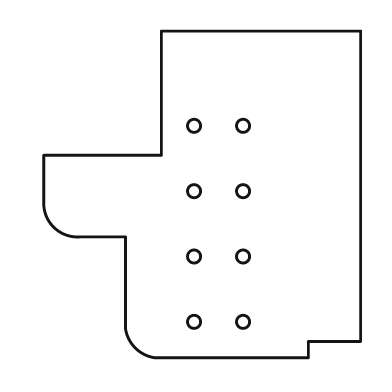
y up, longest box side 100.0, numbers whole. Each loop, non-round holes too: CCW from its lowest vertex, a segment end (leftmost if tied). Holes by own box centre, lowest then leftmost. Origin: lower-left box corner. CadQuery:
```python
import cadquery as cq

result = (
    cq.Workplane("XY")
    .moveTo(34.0, 0.0)
    .lineTo(81.0, 0.0)
    .lineTo(81.0, 5.0)
    .lineTo(97.0, 5.0)
    .lineTo(97.0, 100.0)
    .lineTo(36.0, 100.0)
    .lineTo(36.0, 62.0)
    .lineTo(0.0, 62.0)
    .lineTo(0.0, 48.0)
    .threePointArc((3.0, 40.0), (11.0, 37.0))
    .lineTo(25.0, 37.0)
    .lineTo(25.0, 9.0)
    .threePointArc((28.0, 3.0), (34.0, 0.0))
    .close()
    .moveTo(46.0, 11.0)
    .circle(2.0)
    .moveTo(61.0, 11.0)
    .circle(2.0)
    .moveTo(46.0, 31.0)
    .circle(2.0)
    .moveTo(61.0, 31.0)
    .circle(2.0)
    .moveTo(46.0, 51.0)
    .circle(2.0)
    .moveTo(61.0, 51.0)
    .circle(2.0)
    .moveTo(46.0, 71.0)
    .circle(2.0)
    .moveTo(61.0, 71.0)
    .circle(2.0)
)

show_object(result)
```